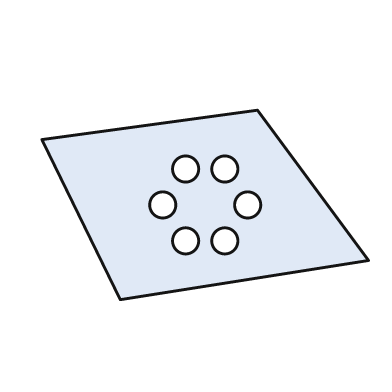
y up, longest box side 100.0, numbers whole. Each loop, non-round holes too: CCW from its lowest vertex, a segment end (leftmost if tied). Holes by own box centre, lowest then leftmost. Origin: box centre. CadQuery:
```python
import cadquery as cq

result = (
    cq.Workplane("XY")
    .moveTo(-26.0, -29.0)
    .lineTo(50.0, -17.0)
    .lineTo(16.0, 29.0)
    .lineTo(-50.0, 20.0)
    .close()
    .moveTo(-6.0, -11.0)
    .circle(4.0)
    .moveTo(6.0, -11.0)
    .circle(4.0)
    .moveTo(-13.0, 0.0)
    .circle(4.0)
    .moveTo(13.0, 0.0)
    .circle(4.0)
    .moveTo(-6.0, 11.0)
    .circle(4.0)
    .moveTo(6.0, 11.0)
    .circle(4.0)
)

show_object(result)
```